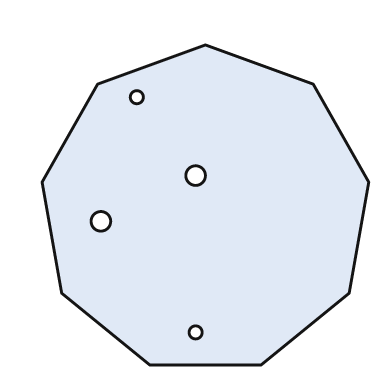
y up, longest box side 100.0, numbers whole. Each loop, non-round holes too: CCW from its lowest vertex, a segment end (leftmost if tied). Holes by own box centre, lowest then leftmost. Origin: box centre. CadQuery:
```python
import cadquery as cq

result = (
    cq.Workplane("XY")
    .moveTo(-17.0, -49.0)
    .lineTo(17.0, -49.0)
    .lineTo(44.0, -27.0)
    .lineTo(50.0, 7.0)
    .lineTo(33.0, 37.0)
    .lineTo(0.0, 49.0)
    .lineTo(-33.0, 37.0)
    .lineTo(-50.0, 7.0)
    .lineTo(-44.0, -27.0)
    .close()
    .moveTo(-3.0, -39.0)
    .circle(2.0)
    .moveTo(-32.0, -5.0)
    .circle(3.0)
    .moveTo(-3.0, 9.0)
    .circle(3.0)
    .moveTo(-21.0, 33.0)
    .circle(2.0)
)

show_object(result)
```